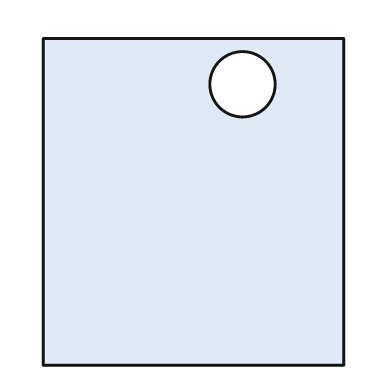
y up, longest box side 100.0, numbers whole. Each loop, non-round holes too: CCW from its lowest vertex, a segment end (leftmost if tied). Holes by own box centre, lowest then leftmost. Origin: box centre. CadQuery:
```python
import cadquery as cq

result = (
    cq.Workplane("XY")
    .moveTo(-46.0, -50.0)
    .lineTo(46.0, -50.0)
    .lineTo(46.0, 50.0)
    .lineTo(-46.0, 50.0)
    .close()
    .moveTo(15.0, 36.0)
    .circle(10.0)
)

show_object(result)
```